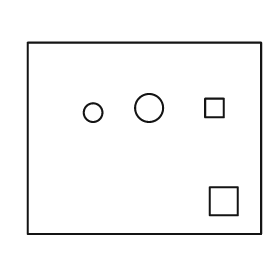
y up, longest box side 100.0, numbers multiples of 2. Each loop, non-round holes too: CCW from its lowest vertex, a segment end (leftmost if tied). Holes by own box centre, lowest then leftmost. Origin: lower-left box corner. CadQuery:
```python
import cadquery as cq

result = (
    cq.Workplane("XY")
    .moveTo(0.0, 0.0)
    .lineTo(100.0, 0.0)
    .lineTo(100.0, 82.0)
    .lineTo(0.0, 82.0)
    .close()
    .moveTo(78.0, 8.0)
    .lineTo(90.0, 8.0)
    .lineTo(90.0, 20.0)
    .lineTo(78.0, 20.0)
    .close()
    .moveTo(28.0, 52.0)
    .circle(4.0)
    .moveTo(52.0, 54.0)
    .circle(6.0)
    .moveTo(76.0, 50.0)
    .lineTo(84.0, 50.0)
    .lineTo(84.0, 58.0)
    .lineTo(76.0, 58.0)
    .close()
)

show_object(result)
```